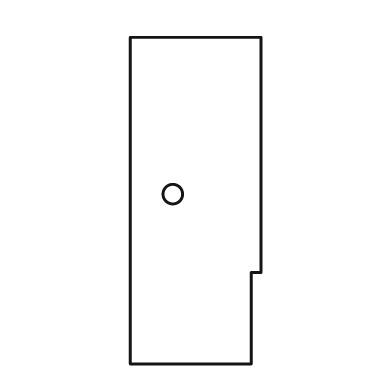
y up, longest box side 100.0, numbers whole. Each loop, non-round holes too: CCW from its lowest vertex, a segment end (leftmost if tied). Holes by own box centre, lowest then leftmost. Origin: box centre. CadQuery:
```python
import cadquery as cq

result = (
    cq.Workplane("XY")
    .moveTo(-20.0, -50.0)
    .lineTo(17.0, -50.0)
    .lineTo(17.0, -22.0)
    .lineTo(20.0, -22.0)
    .lineTo(20.0, 50.0)
    .lineTo(-20.0, 50.0)
    .close()
    .moveTo(-7.0, 2.0)
    .circle(3.0)
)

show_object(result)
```